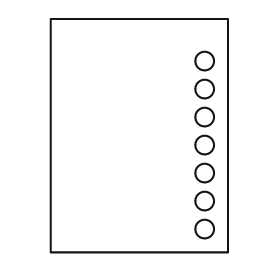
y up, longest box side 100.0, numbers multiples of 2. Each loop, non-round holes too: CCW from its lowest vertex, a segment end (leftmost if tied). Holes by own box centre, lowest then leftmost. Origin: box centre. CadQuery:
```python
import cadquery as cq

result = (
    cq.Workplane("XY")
    .moveTo(-38.0, -50.0)
    .lineTo(38.0, -50.0)
    .lineTo(38.0, 50.0)
    .lineTo(-38.0, 50.0)
    .close()
    .moveTo(28.0, -40.0)
    .circle(4.0)
    .moveTo(28.0, -28.0)
    .circle(4.0)
    .moveTo(28.0, -16.0)
    .circle(4.0)
    .moveTo(28.0, -4.0)
    .circle(4.0)
    .moveTo(28.0, 8.0)
    .circle(4.0)
    .moveTo(28.0, 20.0)
    .circle(4.0)
    .moveTo(28.0, 32.0)
    .circle(4.0)
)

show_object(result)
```